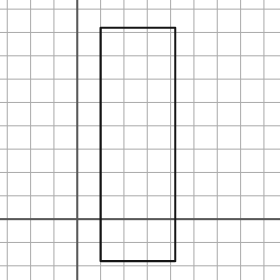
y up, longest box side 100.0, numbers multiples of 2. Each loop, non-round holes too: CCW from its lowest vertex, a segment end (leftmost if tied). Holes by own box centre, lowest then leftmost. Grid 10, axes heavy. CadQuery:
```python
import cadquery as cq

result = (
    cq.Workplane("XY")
    .moveTo(10.0, -18.0)
    .lineTo(42.0, -18.0)
    .lineTo(42.0, 82.0)
    .lineTo(10.0, 82.0)
    .close()
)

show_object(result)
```